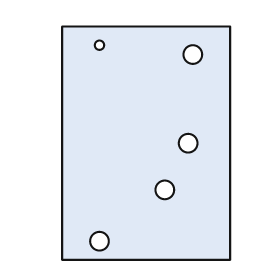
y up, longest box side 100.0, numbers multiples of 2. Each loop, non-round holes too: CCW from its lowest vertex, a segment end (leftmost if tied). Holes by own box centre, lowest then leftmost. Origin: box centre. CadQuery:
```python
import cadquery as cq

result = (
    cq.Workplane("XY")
    .moveTo(-36.0, -50.0)
    .lineTo(36.0, -50.0)
    .lineTo(36.0, 50.0)
    .lineTo(-36.0, 50.0)
    .close()
    .moveTo(-20.0, -42.0)
    .circle(4.0)
    .moveTo(8.0, -20.0)
    .circle(4.0)
    .moveTo(18.0, 0.0)
    .circle(4.0)
    .moveTo(20.0, 38.0)
    .circle(4.0)
    .moveTo(-20.0, 42.0)
    .circle(2.0)
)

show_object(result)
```